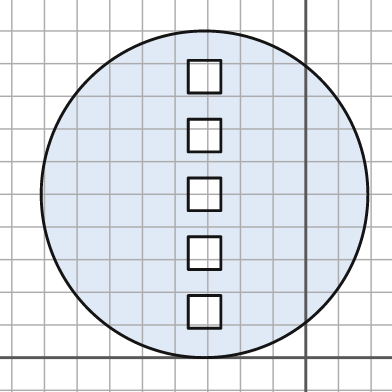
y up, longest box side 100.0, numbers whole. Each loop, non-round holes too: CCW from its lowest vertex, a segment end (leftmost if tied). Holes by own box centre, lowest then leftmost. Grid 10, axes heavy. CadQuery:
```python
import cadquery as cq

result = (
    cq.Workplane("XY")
    .moveTo(-31.0, 50.0)
    .circle(50.0)
    .moveTo(-36.0, 9.0)
    .lineTo(-26.0, 9.0)
    .lineTo(-26.0, 19.0)
    .lineTo(-36.0, 19.0)
    .close()
    .moveTo(-36.0, 27.0)
    .lineTo(-26.0, 27.0)
    .lineTo(-26.0, 37.0)
    .lineTo(-36.0, 37.0)
    .close()
    .moveTo(-36.0, 45.0)
    .lineTo(-26.0, 45.0)
    .lineTo(-26.0, 55.0)
    .lineTo(-36.0, 55.0)
    .close()
    .moveTo(-36.0, 63.0)
    .lineTo(-26.0, 63.0)
    .lineTo(-26.0, 73.0)
    .lineTo(-36.0, 73.0)
    .close()
    .moveTo(-36.0, 81.0)
    .lineTo(-26.0, 81.0)
    .lineTo(-26.0, 91.0)
    .lineTo(-36.0, 91.0)
    .close()
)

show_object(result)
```